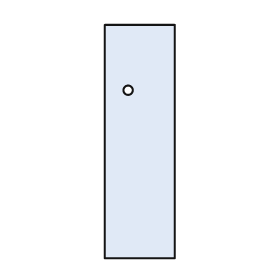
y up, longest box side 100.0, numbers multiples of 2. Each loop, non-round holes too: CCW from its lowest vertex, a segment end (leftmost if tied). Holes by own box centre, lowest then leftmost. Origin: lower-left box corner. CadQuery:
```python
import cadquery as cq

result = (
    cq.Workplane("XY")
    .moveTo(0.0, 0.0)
    .lineTo(30.0, 0.0)
    .lineTo(30.0, 100.0)
    .lineTo(0.0, 100.0)
    .close()
    .moveTo(10.0, 72.0)
    .circle(2.0)
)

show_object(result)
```